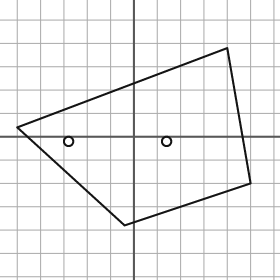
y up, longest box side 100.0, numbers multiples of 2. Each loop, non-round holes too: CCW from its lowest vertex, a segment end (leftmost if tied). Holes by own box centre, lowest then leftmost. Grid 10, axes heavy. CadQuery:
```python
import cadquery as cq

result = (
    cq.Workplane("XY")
    .moveTo(-4.0, -38.0)
    .lineTo(50.0, -20.0)
    .lineTo(40.0, 38.0)
    .lineTo(-50.0, 4.0)
    .close()
    .moveTo(-28.0, -2.0)
    .circle(2.0)
    .moveTo(14.0, -2.0)
    .circle(2.0)
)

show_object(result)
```